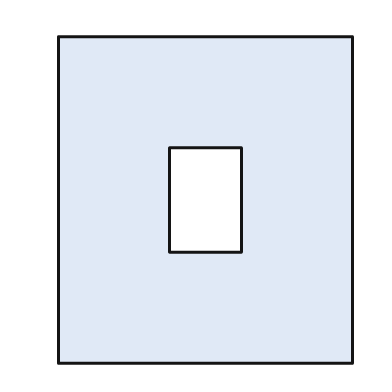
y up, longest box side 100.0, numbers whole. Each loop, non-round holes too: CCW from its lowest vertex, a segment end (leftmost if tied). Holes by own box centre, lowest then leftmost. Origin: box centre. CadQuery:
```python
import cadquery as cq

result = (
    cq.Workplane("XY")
    .moveTo(-45.0, -50.0)
    .lineTo(45.0, -50.0)
    .lineTo(45.0, 50.0)
    .lineTo(-45.0, 50.0)
    .close()
    .moveTo(-11.0, -16.0)
    .lineTo(11.0, -16.0)
    .lineTo(11.0, 16.0)
    .lineTo(-11.0, 16.0)
    .close()
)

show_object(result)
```